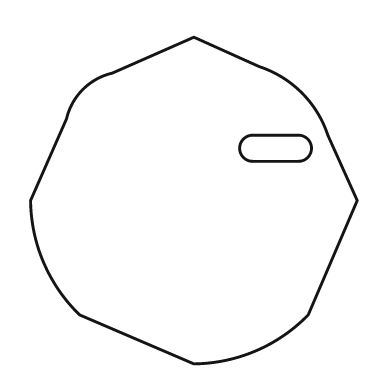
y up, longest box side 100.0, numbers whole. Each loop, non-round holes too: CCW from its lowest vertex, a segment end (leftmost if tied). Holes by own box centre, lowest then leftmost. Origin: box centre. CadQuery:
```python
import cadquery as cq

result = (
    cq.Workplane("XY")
    .moveTo(0.0, -50.0)
    .threePointArc((19.0, -46.0), (35.0, -35.0))
    .lineTo(50.0, 0.0)
    .lineTo(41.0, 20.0)
    .threePointArc((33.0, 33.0), (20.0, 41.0))
    .lineTo(0.0, 50.0)
    .lineTo(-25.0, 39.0)
    .threePointArc((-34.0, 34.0), (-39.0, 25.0))
    .lineTo(-50.0, 0.0)
    .threePointArc((-46.0, -19.0), (-35.0, -35.0))
    .close()
    .moveTo(18.0, 12.0)
    .lineTo(32.0, 12.0)
    .threePointArc((36.0, 16.0), (32.0, 20.0))
    .lineTo(18.0, 20.0)
    .threePointArc((14.0, 16.0), (18.0, 12.0))
    .close()
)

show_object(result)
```